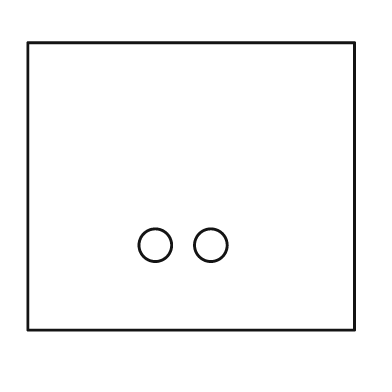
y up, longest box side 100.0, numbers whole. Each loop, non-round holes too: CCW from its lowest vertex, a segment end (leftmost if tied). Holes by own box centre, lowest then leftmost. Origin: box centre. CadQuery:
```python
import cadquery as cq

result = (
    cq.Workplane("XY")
    .moveTo(-50.0, -44.0)
    .lineTo(50.0, -44.0)
    .lineTo(50.0, 44.0)
    .lineTo(-50.0, 44.0)
    .close()
    .moveTo(-11.0, -18.0)
    .circle(5.0)
    .moveTo(6.0, -18.0)
    .circle(5.0)
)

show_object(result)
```